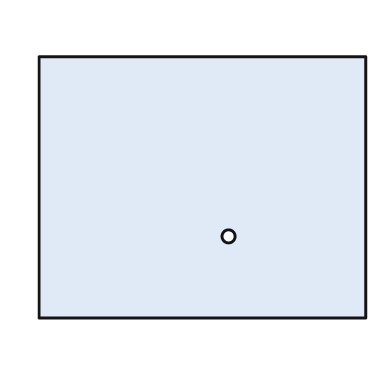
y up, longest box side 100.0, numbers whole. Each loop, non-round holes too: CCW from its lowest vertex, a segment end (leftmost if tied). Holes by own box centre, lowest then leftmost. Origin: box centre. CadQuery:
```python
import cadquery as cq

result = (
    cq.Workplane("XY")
    .moveTo(-50.0, -40.0)
    .lineTo(50.0, -40.0)
    .lineTo(50.0, 40.0)
    .lineTo(-50.0, 40.0)
    .close()
    .moveTo(8.0, -15.0)
    .circle(2.0)
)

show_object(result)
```